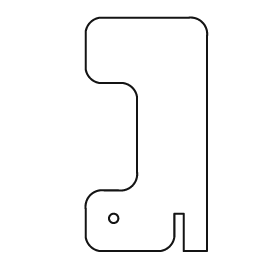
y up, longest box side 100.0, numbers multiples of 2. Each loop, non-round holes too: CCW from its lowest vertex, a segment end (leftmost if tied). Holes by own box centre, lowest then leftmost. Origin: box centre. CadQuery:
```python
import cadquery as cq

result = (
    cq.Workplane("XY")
    .moveTo(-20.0, -50.0)
    .lineTo(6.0, -50.0)
    .threePointArc((10.0, -48.0), (12.0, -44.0))
    .lineTo(12.0, -34.0)
    .lineTo(16.0, -34.0)
    .lineTo(16.0, -50.0)
    .lineTo(26.0, -50.0)
    .lineTo(26.0, 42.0)
    .threePointArc((24.0, 48.0), (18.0, 50.0))
    .lineTo(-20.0, 50.0)
    .threePointArc((-24.0, 48.0), (-26.0, 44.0))
    .lineTo(-26.0, 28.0)
    .threePointArc((-24.0, 24.0), (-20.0, 22.0))
    .lineTo(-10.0, 22.0)
    .threePointArc((-6.0, 20.0), (-4.0, 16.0))
    .lineTo(-4.0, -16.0)
    .threePointArc((-6.0, -22.0), (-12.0, -24.0))
    .lineTo(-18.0, -24.0)
    .threePointArc((-24.0, -26.0), (-26.0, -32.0))
    .lineTo(-26.0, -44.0)
    .threePointArc((-24.0, -48.0), (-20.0, -50.0))
    .close()
    .moveTo(-14.0, -36.0)
    .circle(2.0)
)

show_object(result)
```